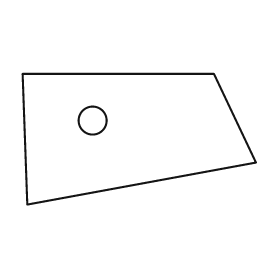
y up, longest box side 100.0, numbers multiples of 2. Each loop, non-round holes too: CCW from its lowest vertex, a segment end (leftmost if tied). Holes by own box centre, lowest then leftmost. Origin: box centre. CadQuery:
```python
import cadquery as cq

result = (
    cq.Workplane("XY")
    .moveTo(-48.0, -28.0)
    .lineTo(50.0, -10.0)
    .lineTo(32.0, 28.0)
    .lineTo(-50.0, 28.0)
    .close()
    .moveTo(-20.0, 8.0)
    .circle(6.0)
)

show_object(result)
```